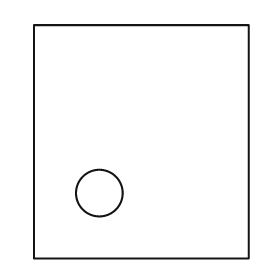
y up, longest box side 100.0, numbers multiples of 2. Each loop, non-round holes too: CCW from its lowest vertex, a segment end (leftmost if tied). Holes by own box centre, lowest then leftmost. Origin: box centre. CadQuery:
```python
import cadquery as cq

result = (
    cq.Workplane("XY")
    .moveTo(-46.0, -50.0)
    .lineTo(46.0, -50.0)
    .lineTo(46.0, 50.0)
    .lineTo(-46.0, 50.0)
    .close()
    .moveTo(-18.0, -22.0)
    .circle(10.0)
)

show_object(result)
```